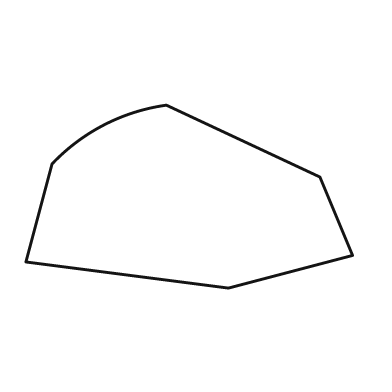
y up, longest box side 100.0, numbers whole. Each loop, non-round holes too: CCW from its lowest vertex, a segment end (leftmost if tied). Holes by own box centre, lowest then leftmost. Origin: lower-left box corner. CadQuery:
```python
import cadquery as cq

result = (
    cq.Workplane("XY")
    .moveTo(62.0, 0.0)
    .lineTo(100.0, 10.0)
    .lineTo(90.0, 34.0)
    .lineTo(43.0, 56.0)
    .threePointArc((24.0, 50.0), (8.0, 38.0))
    .lineTo(0.0, 8.0)
    .close()
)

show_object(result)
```